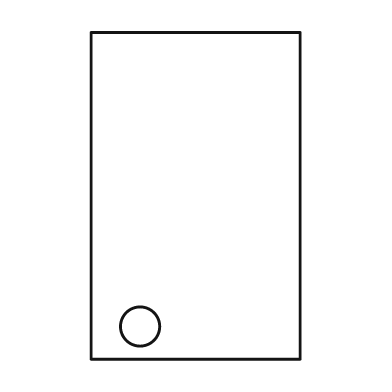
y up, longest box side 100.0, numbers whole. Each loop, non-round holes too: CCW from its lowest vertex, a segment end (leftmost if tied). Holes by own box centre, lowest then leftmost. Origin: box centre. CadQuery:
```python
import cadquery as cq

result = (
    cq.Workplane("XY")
    .moveTo(-32.0, -50.0)
    .lineTo(32.0, -50.0)
    .lineTo(32.0, 50.0)
    .lineTo(-32.0, 50.0)
    .close()
    .moveTo(-17.0, -40.0)
    .circle(6.0)
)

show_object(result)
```